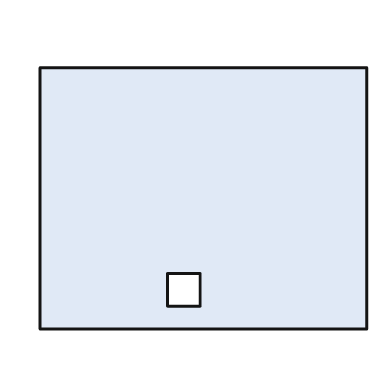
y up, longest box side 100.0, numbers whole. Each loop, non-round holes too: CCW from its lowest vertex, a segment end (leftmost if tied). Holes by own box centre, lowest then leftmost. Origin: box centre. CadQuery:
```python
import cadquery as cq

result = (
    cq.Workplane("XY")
    .moveTo(-50.0, -40.0)
    .lineTo(50.0, -40.0)
    .lineTo(50.0, 40.0)
    .lineTo(-50.0, 40.0)
    .close()
    .moveTo(-11.0, -33.0)
    .lineTo(-1.0, -33.0)
    .lineTo(-1.0, -23.0)
    .lineTo(-11.0, -23.0)
    .close()
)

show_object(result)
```